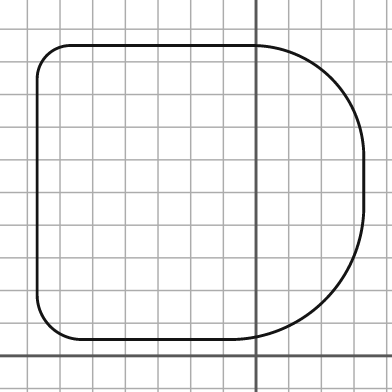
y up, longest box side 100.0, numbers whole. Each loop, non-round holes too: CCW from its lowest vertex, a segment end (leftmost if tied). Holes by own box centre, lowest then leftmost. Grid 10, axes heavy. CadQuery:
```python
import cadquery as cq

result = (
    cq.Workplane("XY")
    .moveTo(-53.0, 5.0)
    .lineTo(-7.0, 5.0)
    .threePointArc((21.0, 17.0), (33.0, 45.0))
    .lineTo(33.0, 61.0)
    .threePointArc((23.0, 85.0), (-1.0, 95.0))
    .lineTo(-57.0, 95.0)
    .threePointArc((-64.0, 92.0), (-67.0, 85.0))
    .lineTo(-67.0, 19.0)
    .threePointArc((-63.0, 9.0), (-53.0, 5.0))
    .close()
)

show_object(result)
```